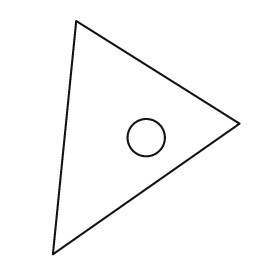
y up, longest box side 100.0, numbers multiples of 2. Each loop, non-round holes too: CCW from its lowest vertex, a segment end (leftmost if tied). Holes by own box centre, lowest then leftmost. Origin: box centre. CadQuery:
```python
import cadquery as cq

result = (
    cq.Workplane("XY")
    .moveTo(-40.0, -50.0)
    .lineTo(40.0, 6.0)
    .lineTo(-30.0, 50.0)
    .close()
    .moveTo(0.0, 0.0)
    .circle(8.0)
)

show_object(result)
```